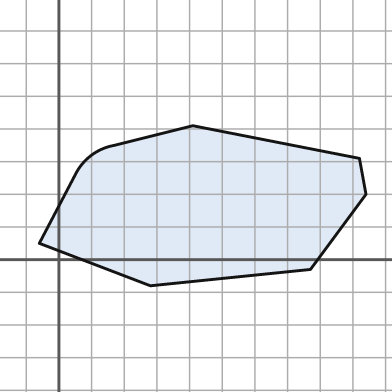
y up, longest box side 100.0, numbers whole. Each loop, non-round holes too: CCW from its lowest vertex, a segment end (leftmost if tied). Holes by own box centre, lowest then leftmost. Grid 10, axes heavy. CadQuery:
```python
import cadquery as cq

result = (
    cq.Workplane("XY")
    .moveTo(28.0, -8.0)
    .lineTo(77.0, -3.0)
    .lineTo(94.0, 20.0)
    .lineTo(92.0, 31.0)
    .lineTo(41.0, 41.0)
    .lineTo(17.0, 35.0)
    .threePointArc((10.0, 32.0), (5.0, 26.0))
    .lineTo(-6.0, 5.0)
    .close()
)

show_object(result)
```